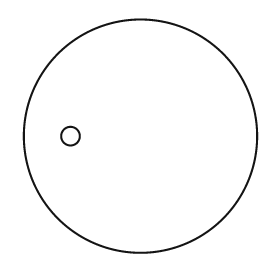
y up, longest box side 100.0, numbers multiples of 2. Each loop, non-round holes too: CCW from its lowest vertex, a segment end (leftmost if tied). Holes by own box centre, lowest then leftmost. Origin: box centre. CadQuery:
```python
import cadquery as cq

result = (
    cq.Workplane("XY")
    .moveTo(0.0, 0.0)
    .circle(50.0)
    .moveTo(-30.0, 0.0)
    .circle(4.0)
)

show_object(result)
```